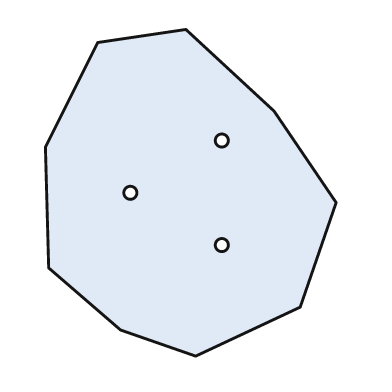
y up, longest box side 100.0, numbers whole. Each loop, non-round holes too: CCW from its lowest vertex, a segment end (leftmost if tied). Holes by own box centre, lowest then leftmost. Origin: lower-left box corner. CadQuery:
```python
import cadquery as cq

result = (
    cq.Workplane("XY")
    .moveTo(46.0, 0.0)
    .lineTo(78.0, 15.0)
    .lineTo(89.0, 47.0)
    .lineTo(70.0, 75.0)
    .lineTo(43.0, 100.0)
    .lineTo(16.0, 96.0)
    .lineTo(0.0, 64.0)
    .lineTo(1.0, 27.0)
    .lineTo(23.0, 8.0)
    .close()
    .moveTo(54.0, 34.0)
    .circle(2.0)
    .moveTo(26.0, 50.0)
    .circle(2.0)
    .moveTo(54.0, 66.0)
    .circle(2.0)
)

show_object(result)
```